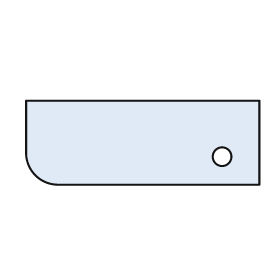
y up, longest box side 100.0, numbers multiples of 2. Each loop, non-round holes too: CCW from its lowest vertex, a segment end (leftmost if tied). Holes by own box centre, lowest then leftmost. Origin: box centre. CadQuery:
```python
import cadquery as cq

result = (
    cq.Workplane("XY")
    .moveTo(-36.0, -18.0)
    .lineTo(50.0, -18.0)
    .lineTo(50.0, 18.0)
    .lineTo(-50.0, 18.0)
    .lineTo(-50.0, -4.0)
    .threePointArc((-46.0, -14.0), (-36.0, -18.0))
    .close()
    .moveTo(34.0, -6.0)
    .circle(4.0)
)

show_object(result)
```